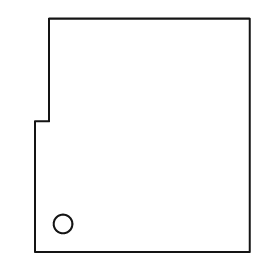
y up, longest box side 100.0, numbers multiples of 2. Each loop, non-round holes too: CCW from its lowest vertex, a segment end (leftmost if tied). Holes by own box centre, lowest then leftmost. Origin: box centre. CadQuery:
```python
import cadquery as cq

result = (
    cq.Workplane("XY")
    .moveTo(-46.0, -50.0)
    .lineTo(46.0, -50.0)
    .lineTo(46.0, 50.0)
    .lineTo(-40.0, 50.0)
    .lineTo(-40.0, 6.0)
    .lineTo(-46.0, 6.0)
    .close()
    .moveTo(-34.0, -38.0)
    .circle(4.0)
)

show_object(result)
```